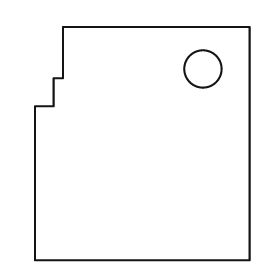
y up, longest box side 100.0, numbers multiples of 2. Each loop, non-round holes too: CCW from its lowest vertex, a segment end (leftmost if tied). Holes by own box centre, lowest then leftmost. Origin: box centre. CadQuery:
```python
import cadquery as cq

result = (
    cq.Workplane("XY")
    .moveTo(-46.0, -50.0)
    .lineTo(46.0, -50.0)
    .lineTo(46.0, 50.0)
    .lineTo(-34.0, 50.0)
    .lineTo(-34.0, 28.0)
    .lineTo(-38.0, 28.0)
    .lineTo(-38.0, 16.0)
    .lineTo(-46.0, 16.0)
    .close()
    .moveTo(26.0, 32.0)
    .circle(8.0)
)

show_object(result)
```